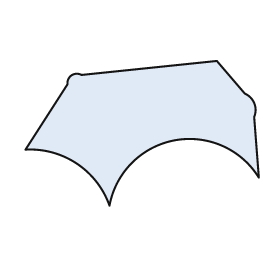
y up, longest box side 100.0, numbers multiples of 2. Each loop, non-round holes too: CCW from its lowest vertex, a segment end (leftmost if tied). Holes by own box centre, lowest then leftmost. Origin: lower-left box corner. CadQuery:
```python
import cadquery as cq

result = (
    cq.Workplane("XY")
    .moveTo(36.0, 0.0)
    .threePointArc((64.0, 28.0), (100.0, 12.0))
    .lineTo(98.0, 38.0)
    .threePointArc((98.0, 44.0), (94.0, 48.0))
    .lineTo(82.0, 62.0)
    .lineTo(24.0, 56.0)
    .threePointArc((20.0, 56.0), (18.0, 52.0))
    .lineTo(0.0, 24.0)
    .threePointArc((22.0, 18.0), (36.0, 0.0))
    .close()
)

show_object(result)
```